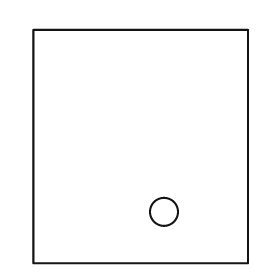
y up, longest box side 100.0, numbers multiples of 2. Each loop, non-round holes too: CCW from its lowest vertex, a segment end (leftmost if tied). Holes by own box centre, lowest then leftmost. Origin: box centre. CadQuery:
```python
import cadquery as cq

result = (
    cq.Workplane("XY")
    .moveTo(-46.0, -50.0)
    .lineTo(46.0, -50.0)
    .lineTo(46.0, 50.0)
    .lineTo(-46.0, 50.0)
    .close()
    .moveTo(10.0, -28.0)
    .circle(6.0)
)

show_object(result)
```